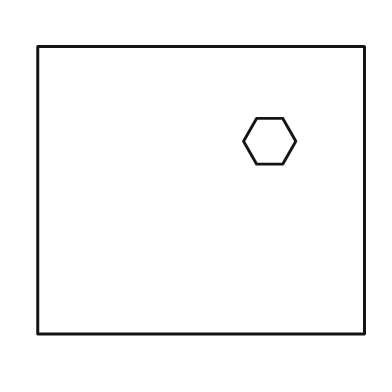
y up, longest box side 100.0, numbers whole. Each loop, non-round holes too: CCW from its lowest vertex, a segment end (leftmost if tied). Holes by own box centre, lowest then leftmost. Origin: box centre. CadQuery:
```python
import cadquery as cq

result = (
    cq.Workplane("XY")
    .moveTo(-50.0, -44.0)
    .lineTo(50.0, -44.0)
    .lineTo(50.0, 44.0)
    .lineTo(-50.0, 44.0)
    .close()
    .moveTo(17.0, 8.0)
    .lineTo(25.0, 8.0)
    .lineTo(29.0, 15.0)
    .lineTo(25.0, 22.0)
    .lineTo(17.0, 22.0)
    .lineTo(13.0, 15.0)
    .close()
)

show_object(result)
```